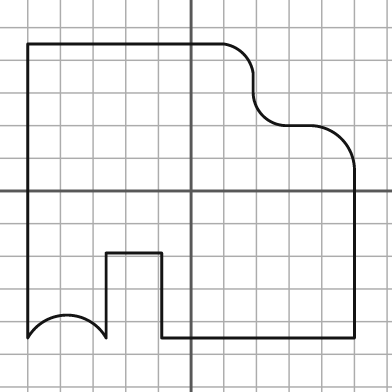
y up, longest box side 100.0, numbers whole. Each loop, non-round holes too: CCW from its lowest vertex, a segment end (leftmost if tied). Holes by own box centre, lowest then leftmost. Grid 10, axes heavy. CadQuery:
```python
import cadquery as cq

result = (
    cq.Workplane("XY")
    .moveTo(-50.0, -45.0)
    .threePointArc((-38.0, -38.0), (-26.0, -45.0))
    .lineTo(-26.0, -19.0)
    .lineTo(-9.0, -19.0)
    .lineTo(-9.0, -45.0)
    .lineTo(50.0, -45.0)
    .lineTo(50.0, 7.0)
    .threePointArc((46.0, 16.0), (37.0, 20.0))
    .lineTo(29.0, 20.0)
    .threePointArc((22.0, 23.0), (19.0, 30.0))
    .lineTo(19.0, 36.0)
    .threePointArc((16.0, 42.0), (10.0, 45.0))
    .lineTo(-50.0, 45.0)
    .close()
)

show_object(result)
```